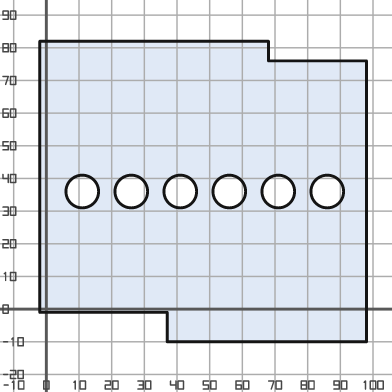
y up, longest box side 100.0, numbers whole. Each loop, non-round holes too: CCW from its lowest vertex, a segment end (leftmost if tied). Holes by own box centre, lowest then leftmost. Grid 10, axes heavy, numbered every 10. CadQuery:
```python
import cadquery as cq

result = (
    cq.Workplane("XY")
    .moveTo(37.0, -10.0)
    .lineTo(98.0, -10.0)
    .lineTo(98.0, 76.0)
    .lineTo(68.0, 76.0)
    .lineTo(68.0, 82.0)
    .lineTo(-2.0, 82.0)
    .lineTo(-2.0, -1.0)
    .lineTo(37.0, -1.0)
    .close()
    .moveTo(11.0, 36.0)
    .circle(5.0)
    .moveTo(26.0, 36.0)
    .circle(5.0)
    .moveTo(41.0, 36.0)
    .circle(5.0)
    .moveTo(56.0, 36.0)
    .circle(5.0)
    .moveTo(71.0, 36.0)
    .circle(5.0)
    .moveTo(86.0, 36.0)
    .circle(5.0)
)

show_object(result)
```